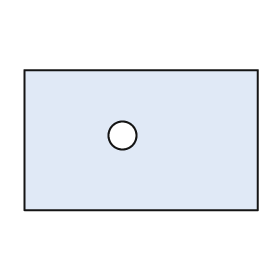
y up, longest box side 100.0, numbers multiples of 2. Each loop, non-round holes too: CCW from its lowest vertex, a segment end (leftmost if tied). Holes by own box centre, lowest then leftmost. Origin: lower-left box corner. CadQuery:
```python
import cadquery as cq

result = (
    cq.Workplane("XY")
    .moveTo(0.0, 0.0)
    .lineTo(100.0, 0.0)
    .lineTo(100.0, 60.0)
    .lineTo(0.0, 60.0)
    .close()
    .moveTo(42.0, 32.0)
    .circle(6.0)
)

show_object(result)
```